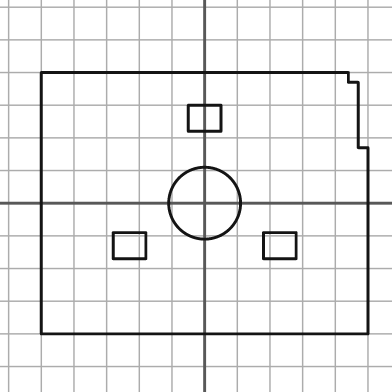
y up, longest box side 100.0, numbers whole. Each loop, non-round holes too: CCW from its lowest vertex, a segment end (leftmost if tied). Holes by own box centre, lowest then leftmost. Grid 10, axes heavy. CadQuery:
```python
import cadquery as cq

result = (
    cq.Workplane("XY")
    .moveTo(-50.0, -40.0)
    .lineTo(50.0, -40.0)
    .lineTo(50.0, 17.0)
    .lineTo(47.0, 17.0)
    .lineTo(47.0, 37.0)
    .lineTo(44.0, 37.0)
    .lineTo(44.0, 40.0)
    .lineTo(-50.0, 40.0)
    .close()
    .moveTo(-28.0, -17.0)
    .lineTo(-18.0, -17.0)
    .lineTo(-18.0, -9.0)
    .lineTo(-28.0, -9.0)
    .close()
    .moveTo(18.0, -17.0)
    .lineTo(28.0, -17.0)
    .lineTo(28.0, -9.0)
    .lineTo(18.0, -9.0)
    .close()
    .moveTo(0.0, 0.0)
    .circle(11.0)
    .moveTo(-5.0, 22.0)
    .lineTo(5.0, 22.0)
    .lineTo(5.0, 30.0)
    .lineTo(-5.0, 30.0)
    .close()
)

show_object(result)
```